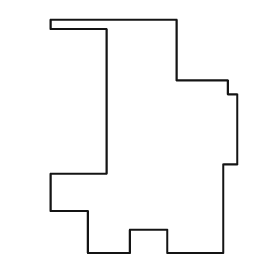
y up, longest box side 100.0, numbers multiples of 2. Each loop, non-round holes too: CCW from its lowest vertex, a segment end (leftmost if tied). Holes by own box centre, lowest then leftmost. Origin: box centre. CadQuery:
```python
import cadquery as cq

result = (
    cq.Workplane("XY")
    .moveTo(-24.0, -50.0)
    .lineTo(-6.0, -50.0)
    .lineTo(-6.0, -40.0)
    .lineTo(10.0, -40.0)
    .lineTo(10.0, -50.0)
    .lineTo(34.0, -50.0)
    .lineTo(34.0, -12.0)
    .lineTo(40.0, -12.0)
    .lineTo(40.0, 18.0)
    .lineTo(36.0, 18.0)
    .lineTo(36.0, 24.0)
    .lineTo(14.0, 24.0)
    .lineTo(14.0, 50.0)
    .lineTo(-40.0, 50.0)
    .lineTo(-40.0, 46.0)
    .lineTo(-16.0, 46.0)
    .lineTo(-16.0, -16.0)
    .lineTo(-40.0, -16.0)
    .lineTo(-40.0, -32.0)
    .lineTo(-24.0, -32.0)
    .close()
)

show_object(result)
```